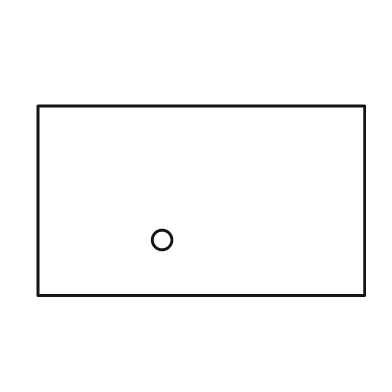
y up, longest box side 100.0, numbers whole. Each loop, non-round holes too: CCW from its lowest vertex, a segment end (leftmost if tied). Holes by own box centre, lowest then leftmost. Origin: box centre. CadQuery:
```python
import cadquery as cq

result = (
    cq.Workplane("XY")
    .moveTo(-50.0, -29.0)
    .lineTo(50.0, -29.0)
    .lineTo(50.0, 29.0)
    .lineTo(-50.0, 29.0)
    .close()
    .moveTo(-12.0, -12.0)
    .circle(3.0)
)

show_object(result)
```